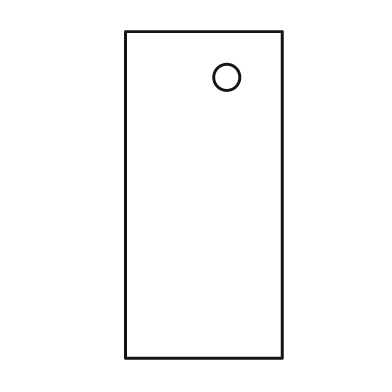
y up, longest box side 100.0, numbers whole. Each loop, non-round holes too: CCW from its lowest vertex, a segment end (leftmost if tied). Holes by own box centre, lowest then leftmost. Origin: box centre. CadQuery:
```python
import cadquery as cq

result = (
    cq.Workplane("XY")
    .moveTo(-24.0, -50.0)
    .lineTo(24.0, -50.0)
    .lineTo(24.0, 50.0)
    .lineTo(-24.0, 50.0)
    .close()
    .moveTo(7.0, 36.0)
    .circle(4.0)
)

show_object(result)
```